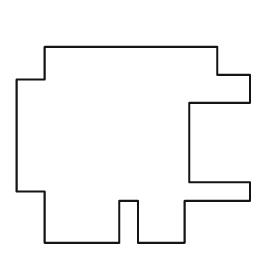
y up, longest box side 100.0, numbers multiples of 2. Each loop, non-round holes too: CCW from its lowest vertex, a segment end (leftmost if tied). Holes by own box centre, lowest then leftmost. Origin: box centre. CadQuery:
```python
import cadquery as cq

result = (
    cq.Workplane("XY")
    .moveTo(-38.0, -42.0)
    .lineTo(-6.0, -42.0)
    .lineTo(-6.0, -24.0)
    .lineTo(2.0, -24.0)
    .lineTo(2.0, -42.0)
    .lineTo(22.0, -42.0)
    .lineTo(22.0, -24.0)
    .lineTo(50.0, -24.0)
    .lineTo(50.0, -16.0)
    .lineTo(24.0, -16.0)
    .lineTo(24.0, 18.0)
    .lineTo(50.0, 18.0)
    .lineTo(50.0, 30.0)
    .lineTo(36.0, 30.0)
    .lineTo(36.0, 42.0)
    .lineTo(-38.0, 42.0)
    .lineTo(-38.0, 28.0)
    .lineTo(-50.0, 28.0)
    .lineTo(-50.0, -20.0)
    .lineTo(-38.0, -20.0)
    .close()
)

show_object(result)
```